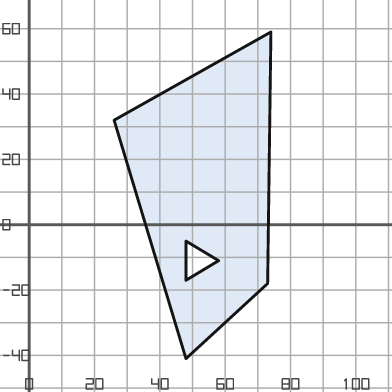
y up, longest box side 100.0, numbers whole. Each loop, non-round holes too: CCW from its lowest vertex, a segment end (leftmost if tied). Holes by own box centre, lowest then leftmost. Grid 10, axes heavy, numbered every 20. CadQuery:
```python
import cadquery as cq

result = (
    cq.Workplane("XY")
    .moveTo(48.0, -41.0)
    .lineTo(73.0, -18.0)
    .lineTo(74.0, 59.0)
    .lineTo(26.0, 32.0)
    .close()
    .moveTo(48.0, -17.0)
    .lineTo(58.0, -11.0)
    .lineTo(48.0, -5.0)
    .close()
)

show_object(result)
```